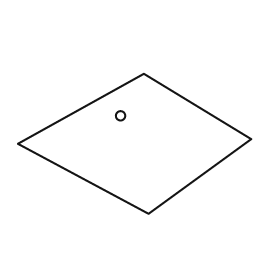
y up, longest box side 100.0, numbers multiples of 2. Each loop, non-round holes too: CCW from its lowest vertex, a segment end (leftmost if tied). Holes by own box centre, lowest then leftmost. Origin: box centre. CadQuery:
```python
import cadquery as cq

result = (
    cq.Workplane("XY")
    .moveTo(6.0, -30.0)
    .lineTo(50.0, 2.0)
    .lineTo(4.0, 30.0)
    .lineTo(-50.0, 0.0)
    .close()
    .moveTo(-6.0, 12.0)
    .circle(2.0)
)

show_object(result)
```